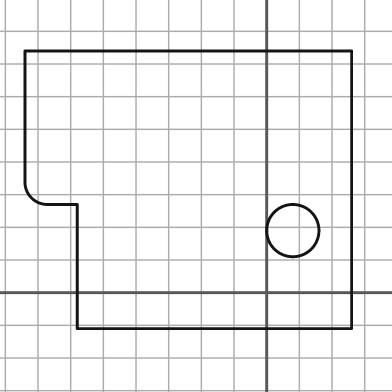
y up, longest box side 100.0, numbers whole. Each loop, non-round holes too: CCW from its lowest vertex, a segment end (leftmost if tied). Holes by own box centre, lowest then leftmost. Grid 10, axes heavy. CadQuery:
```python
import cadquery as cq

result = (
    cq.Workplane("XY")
    .moveTo(-58.0, -11.0)
    .lineTo(26.0, -11.0)
    .lineTo(26.0, 74.0)
    .lineTo(-74.0, 74.0)
    .lineTo(-74.0, 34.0)
    .threePointArc((-72.0, 29.0), (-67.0, 27.0))
    .lineTo(-58.0, 27.0)
    .close()
    .moveTo(8.0, 19.0)
    .circle(8.0)
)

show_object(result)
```